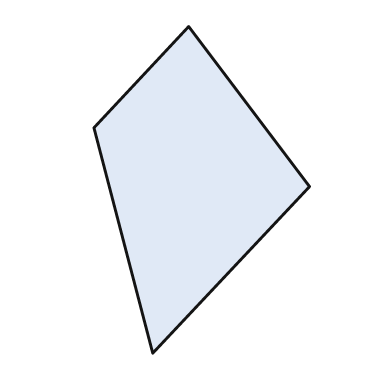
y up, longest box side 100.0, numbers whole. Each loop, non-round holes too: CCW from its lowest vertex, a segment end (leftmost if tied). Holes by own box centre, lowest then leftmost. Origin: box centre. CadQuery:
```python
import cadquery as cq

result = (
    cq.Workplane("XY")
    .moveTo(-15.0, -50.0)
    .lineTo(33.0, 1.0)
    .lineTo(-4.0, 50.0)
    .lineTo(-33.0, 19.0)
    .close()
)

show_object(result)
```